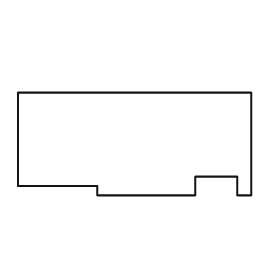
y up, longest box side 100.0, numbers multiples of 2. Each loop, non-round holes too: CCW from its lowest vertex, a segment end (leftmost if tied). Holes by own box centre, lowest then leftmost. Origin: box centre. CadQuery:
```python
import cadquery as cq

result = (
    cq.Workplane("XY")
    .moveTo(-16.0, -22.0)
    .lineTo(26.0, -22.0)
    .lineTo(26.0, -14.0)
    .lineTo(44.0, -14.0)
    .lineTo(44.0, -22.0)
    .lineTo(50.0, -22.0)
    .lineTo(50.0, 22.0)
    .lineTo(-50.0, 22.0)
    .lineTo(-50.0, -18.0)
    .lineTo(-16.0, -18.0)
    .close()
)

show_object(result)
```